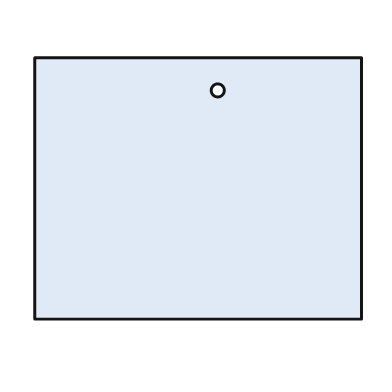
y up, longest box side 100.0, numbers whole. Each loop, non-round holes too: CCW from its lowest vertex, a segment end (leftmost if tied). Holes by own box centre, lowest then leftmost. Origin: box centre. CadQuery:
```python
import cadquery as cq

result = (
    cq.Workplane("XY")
    .moveTo(-50.0, -40.0)
    .lineTo(50.0, -40.0)
    .lineTo(50.0, 40.0)
    .lineTo(-50.0, 40.0)
    .close()
    .moveTo(6.0, 30.0)
    .circle(2.0)
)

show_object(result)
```